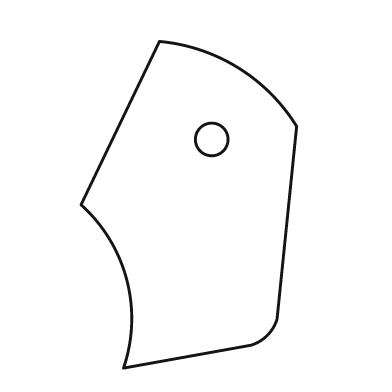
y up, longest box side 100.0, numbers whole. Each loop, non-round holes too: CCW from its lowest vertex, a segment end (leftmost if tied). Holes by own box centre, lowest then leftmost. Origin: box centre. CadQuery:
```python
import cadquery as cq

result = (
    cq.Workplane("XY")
    .moveTo(-20.0, -50.0)
    .lineTo(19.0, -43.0)
    .threePointArc((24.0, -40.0), (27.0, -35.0))
    .lineTo(33.0, 24.0)
    .threePointArc((15.0, 42.0), (-9.0, 50.0))
    .lineTo(-33.0, 0.0)
    .threePointArc((-19.0, -23.0), (-20.0, -50.0))
    .close()
    .moveTo(7.0, 20.0)
    .circle(5.0)
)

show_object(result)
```